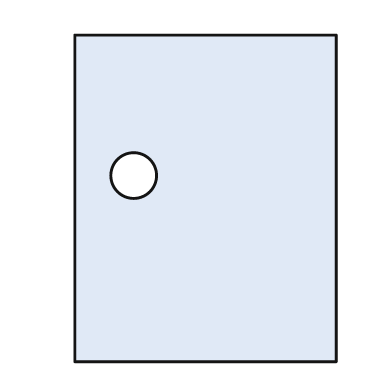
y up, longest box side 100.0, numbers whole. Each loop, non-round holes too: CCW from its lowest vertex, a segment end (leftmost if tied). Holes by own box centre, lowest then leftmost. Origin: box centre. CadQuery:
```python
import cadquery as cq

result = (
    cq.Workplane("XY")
    .moveTo(-40.0, -50.0)
    .lineTo(40.0, -50.0)
    .lineTo(40.0, 50.0)
    .lineTo(-40.0, 50.0)
    .close()
    .moveTo(-22.0, 7.0)
    .circle(7.0)
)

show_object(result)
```